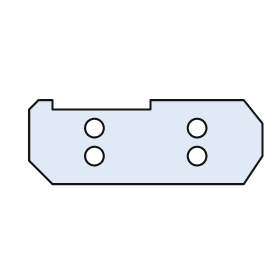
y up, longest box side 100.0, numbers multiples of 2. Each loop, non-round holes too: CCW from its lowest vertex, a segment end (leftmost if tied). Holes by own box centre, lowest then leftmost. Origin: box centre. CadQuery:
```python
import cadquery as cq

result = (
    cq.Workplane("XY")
    .moveTo(-40.0, -18.0)
    .lineTo(42.0, -18.0)
    .lineTo(50.0, -6.0)
    .lineTo(50.0, 8.0)
    .lineTo(42.0, 18.0)
    .lineTo(2.0, 18.0)
    .lineTo(2.0, 14.0)
    .lineTo(-40.0, 14.0)
    .lineTo(-40.0, 18.0)
    .lineTo(-46.0, 18.0)
    .lineTo(-50.0, 14.0)
    .lineTo(-50.0, -8.0)
    .close()
    .moveTo(-22.0, -6.0)
    .circle(4.0)
    .moveTo(22.0, -6.0)
    .circle(4.0)
    .moveTo(-22.0, 6.0)
    .circle(4.0)
    .moveTo(22.0, 6.0)
    .circle(4.0)
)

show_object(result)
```